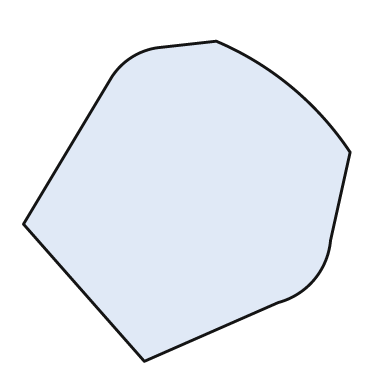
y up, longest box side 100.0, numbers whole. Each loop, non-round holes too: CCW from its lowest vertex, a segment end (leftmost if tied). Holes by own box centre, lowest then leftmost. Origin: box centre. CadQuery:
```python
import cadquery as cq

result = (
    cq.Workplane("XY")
    .moveTo(-13.0, -49.0)
    .lineTo(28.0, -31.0)
    .threePointArc((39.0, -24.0), (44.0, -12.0))
    .lineTo(50.0, 15.0)
    .threePointArc((32.0, 35.0), (9.0, 49.0))
    .lineTo(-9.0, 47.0)
    .threePointArc((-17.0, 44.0), (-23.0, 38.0))
    .lineTo(-50.0, -7.0)
    .close()
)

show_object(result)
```